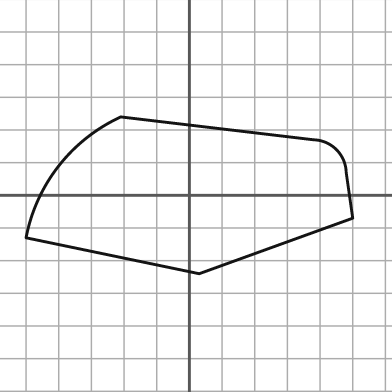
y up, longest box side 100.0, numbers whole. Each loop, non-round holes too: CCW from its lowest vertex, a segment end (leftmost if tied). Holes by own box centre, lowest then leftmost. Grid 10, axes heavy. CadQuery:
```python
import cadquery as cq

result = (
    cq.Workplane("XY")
    .moveTo(3.0, -24.0)
    .lineTo(50.0, -7.0)
    .lineTo(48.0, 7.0)
    .threePointArc((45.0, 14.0), (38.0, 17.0))
    .lineTo(-21.0, 24.0)
    .threePointArc((-40.0, 9.0), (-50.0, -13.0))
    .close()
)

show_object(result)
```